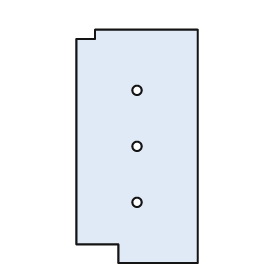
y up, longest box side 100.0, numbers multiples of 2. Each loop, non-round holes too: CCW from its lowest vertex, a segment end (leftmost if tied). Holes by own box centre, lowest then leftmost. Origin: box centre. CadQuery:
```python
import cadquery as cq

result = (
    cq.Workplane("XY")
    .moveTo(-8.0, -50.0)
    .lineTo(26.0, -50.0)
    .lineTo(26.0, 50.0)
    .lineTo(-18.0, 50.0)
    .lineTo(-18.0, 46.0)
    .lineTo(-26.0, 46.0)
    .lineTo(-26.0, -42.0)
    .lineTo(-8.0, -42.0)
    .close()
    .moveTo(0.0, -24.0)
    .circle(2.0)
    .moveTo(0.0, 0.0)
    .circle(2.0)
    .moveTo(0.0, 24.0)
    .circle(2.0)
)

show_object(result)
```